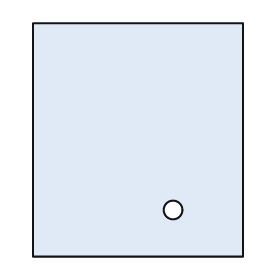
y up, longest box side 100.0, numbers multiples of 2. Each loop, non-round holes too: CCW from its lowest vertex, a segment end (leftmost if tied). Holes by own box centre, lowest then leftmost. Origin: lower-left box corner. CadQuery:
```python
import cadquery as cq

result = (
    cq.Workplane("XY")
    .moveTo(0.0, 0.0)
    .lineTo(90.0, 0.0)
    .lineTo(90.0, 100.0)
    .lineTo(0.0, 100.0)
    .close()
    .moveTo(60.0, 20.0)
    .circle(4.0)
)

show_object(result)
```